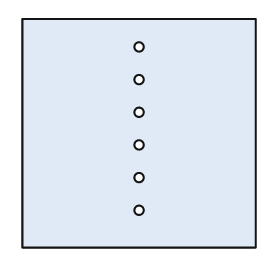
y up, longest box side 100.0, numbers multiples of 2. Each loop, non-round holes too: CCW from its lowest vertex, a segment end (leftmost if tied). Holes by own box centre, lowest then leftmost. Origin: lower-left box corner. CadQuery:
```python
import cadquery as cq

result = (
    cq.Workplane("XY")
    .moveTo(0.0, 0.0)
    .lineTo(100.0, 0.0)
    .lineTo(100.0, 98.0)
    .lineTo(0.0, 98.0)
    .close()
    .moveTo(50.0, 16.0)
    .circle(2.0)
    .moveTo(50.0, 30.0)
    .circle(2.0)
    .moveTo(50.0, 44.0)
    .circle(2.0)
    .moveTo(50.0, 58.0)
    .circle(2.0)
    .moveTo(50.0, 72.0)
    .circle(2.0)
    .moveTo(50.0, 86.0)
    .circle(2.0)
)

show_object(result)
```